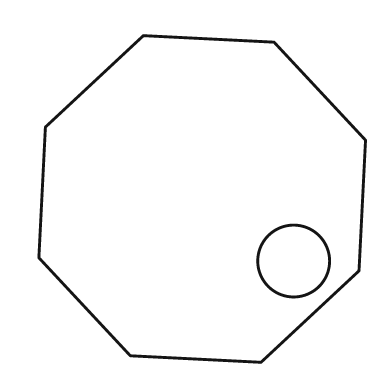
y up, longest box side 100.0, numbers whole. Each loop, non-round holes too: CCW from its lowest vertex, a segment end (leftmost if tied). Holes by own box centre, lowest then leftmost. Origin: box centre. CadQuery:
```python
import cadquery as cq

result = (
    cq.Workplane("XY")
    .moveTo(18.0, -50.0)
    .lineTo(48.0, -22.0)
    .lineTo(50.0, 18.0)
    .lineTo(22.0, 48.0)
    .lineTo(-18.0, 50.0)
    .lineTo(-48.0, 22.0)
    .lineTo(-50.0, -18.0)
    .lineTo(-22.0, -48.0)
    .close()
    .moveTo(28.0, -19.0)
    .circle(11.0)
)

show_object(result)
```